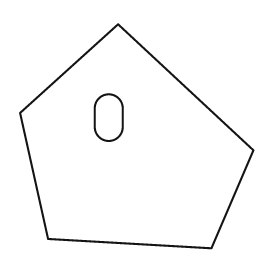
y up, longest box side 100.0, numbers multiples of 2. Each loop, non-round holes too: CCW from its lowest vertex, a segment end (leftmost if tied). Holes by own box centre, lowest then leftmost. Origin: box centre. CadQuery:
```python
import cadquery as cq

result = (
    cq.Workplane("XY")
    .moveTo(32.0, -48.0)
    .lineTo(50.0, -6.0)
    .lineTo(-8.0, 48.0)
    .lineTo(-50.0, 10.0)
    .lineTo(-38.0, -44.0)
    .close()
    .moveTo(-18.0, 4.0)
    .threePointArc((-12.0, -2.0), (-6.0, 4.0))
    .lineTo(-6.0, 12.0)
    .threePointArc((-12.0, 18.0), (-18.0, 12.0))
    .close()
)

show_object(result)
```